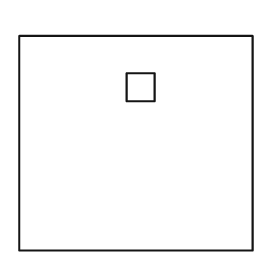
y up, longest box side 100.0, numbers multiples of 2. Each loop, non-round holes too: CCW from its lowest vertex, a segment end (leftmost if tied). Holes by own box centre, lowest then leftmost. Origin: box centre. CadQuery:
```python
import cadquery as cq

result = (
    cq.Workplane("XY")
    .moveTo(-50.0, -46.0)
    .lineTo(50.0, -46.0)
    .lineTo(50.0, 46.0)
    .lineTo(-50.0, 46.0)
    .close()
    .moveTo(-4.0, 18.0)
    .lineTo(8.0, 18.0)
    .lineTo(8.0, 30.0)
    .lineTo(-4.0, 30.0)
    .close()
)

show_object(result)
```